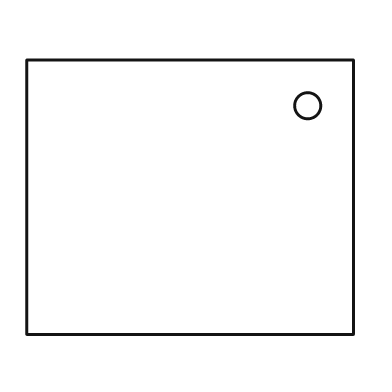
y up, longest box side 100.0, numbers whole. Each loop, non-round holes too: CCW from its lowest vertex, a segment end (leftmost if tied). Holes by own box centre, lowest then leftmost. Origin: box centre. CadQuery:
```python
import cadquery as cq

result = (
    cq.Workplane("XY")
    .moveTo(-50.0, -42.0)
    .lineTo(50.0, -42.0)
    .lineTo(50.0, 42.0)
    .lineTo(-50.0, 42.0)
    .close()
    .moveTo(36.0, 28.0)
    .circle(4.0)
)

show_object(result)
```